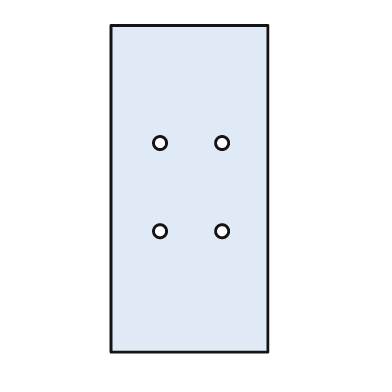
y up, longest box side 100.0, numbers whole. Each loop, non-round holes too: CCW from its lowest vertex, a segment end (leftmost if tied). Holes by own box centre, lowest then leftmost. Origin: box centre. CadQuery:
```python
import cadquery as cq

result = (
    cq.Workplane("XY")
    .moveTo(-24.0, -50.0)
    .lineTo(24.0, -50.0)
    .lineTo(24.0, 50.0)
    .lineTo(-24.0, 50.0)
    .close()
    .moveTo(-9.0, -13.0)
    .circle(2.0)
    .moveTo(10.0, -13.0)
    .circle(2.0)
    .moveTo(-9.0, 14.0)
    .circle(2.0)
    .moveTo(10.0, 14.0)
    .circle(2.0)
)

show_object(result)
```